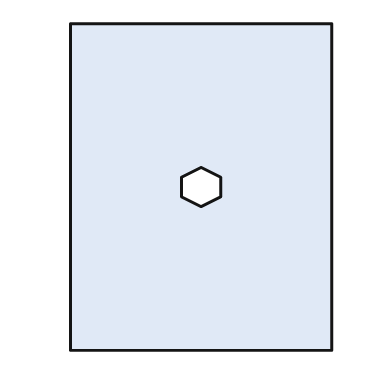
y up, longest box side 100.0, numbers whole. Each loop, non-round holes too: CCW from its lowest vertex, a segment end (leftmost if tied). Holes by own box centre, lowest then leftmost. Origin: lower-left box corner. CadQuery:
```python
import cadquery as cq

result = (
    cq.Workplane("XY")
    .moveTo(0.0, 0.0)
    .lineTo(80.0, 0.0)
    .lineTo(80.0, 100.0)
    .lineTo(0.0, 100.0)
    .close()
    .moveTo(40.0, 44.0)
    .lineTo(46.0, 47.0)
    .lineTo(46.0, 53.0)
    .lineTo(40.0, 56.0)
    .lineTo(34.0, 53.0)
    .lineTo(34.0, 47.0)
    .close()
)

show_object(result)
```